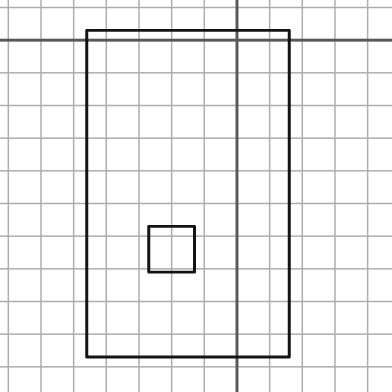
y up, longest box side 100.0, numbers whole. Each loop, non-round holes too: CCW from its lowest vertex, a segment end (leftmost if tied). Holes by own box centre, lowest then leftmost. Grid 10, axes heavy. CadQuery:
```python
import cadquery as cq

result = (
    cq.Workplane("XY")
    .moveTo(-46.0, -97.0)
    .lineTo(16.0, -97.0)
    .lineTo(16.0, 3.0)
    .lineTo(-46.0, 3.0)
    .close()
    .moveTo(-27.0, -71.0)
    .lineTo(-13.0, -71.0)
    .lineTo(-13.0, -57.0)
    .lineTo(-27.0, -57.0)
    .close()
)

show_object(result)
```